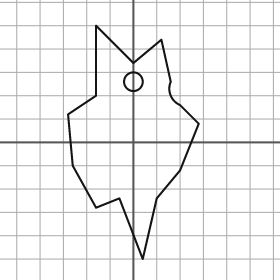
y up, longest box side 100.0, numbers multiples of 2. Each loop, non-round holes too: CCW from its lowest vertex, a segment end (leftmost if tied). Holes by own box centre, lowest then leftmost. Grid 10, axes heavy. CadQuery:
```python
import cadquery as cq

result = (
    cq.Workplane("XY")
    .moveTo(4.0, -50.0)
    .lineTo(10.0, -24.0)
    .lineTo(20.0, -12.0)
    .lineTo(28.0, 8.0)
    .lineTo(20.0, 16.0)
    .threePointArc((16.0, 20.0), (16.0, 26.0))
    .lineTo(12.0, 44.0)
    .lineTo(0.0, 34.0)
    .lineTo(-16.0, 50.0)
    .lineTo(-16.0, 20.0)
    .lineTo(-28.0, 12.0)
    .lineTo(-26.0, -10.0)
    .lineTo(-16.0, -28.0)
    .lineTo(-6.0, -24.0)
    .close()
    .moveTo(0.0, 26.0)
    .circle(4.0)
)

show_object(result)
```